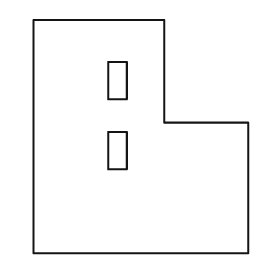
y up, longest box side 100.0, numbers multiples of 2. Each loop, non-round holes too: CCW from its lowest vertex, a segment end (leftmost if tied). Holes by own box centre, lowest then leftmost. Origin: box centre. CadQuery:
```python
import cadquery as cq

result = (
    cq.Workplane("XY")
    .moveTo(-46.0, -50.0)
    .lineTo(46.0, -50.0)
    .lineTo(46.0, 6.0)
    .lineTo(10.0, 6.0)
    .lineTo(10.0, 50.0)
    .lineTo(-46.0, 50.0)
    .close()
    .moveTo(-14.0, -14.0)
    .lineTo(-6.0, -14.0)
    .lineTo(-6.0, 2.0)
    .lineTo(-14.0, 2.0)
    .close()
    .moveTo(-14.0, 16.0)
    .lineTo(-6.0, 16.0)
    .lineTo(-6.0, 32.0)
    .lineTo(-14.0, 32.0)
    .close()
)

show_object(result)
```